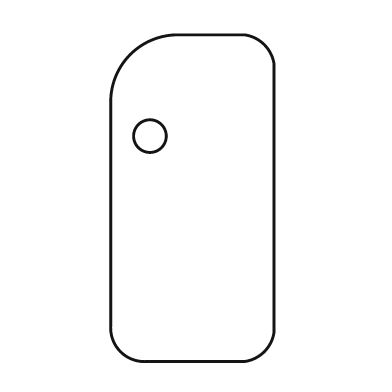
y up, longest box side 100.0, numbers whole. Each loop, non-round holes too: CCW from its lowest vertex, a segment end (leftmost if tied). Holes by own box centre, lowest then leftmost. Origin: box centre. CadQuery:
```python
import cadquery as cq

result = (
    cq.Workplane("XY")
    .moveTo(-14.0, -50.0)
    .lineTo(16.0, -50.0)
    .threePointArc((22.0, -47.0), (25.0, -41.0))
    .lineTo(25.0, 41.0)
    .threePointArc((22.0, 47.0), (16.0, 50.0))
    .lineTo(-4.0, 50.0)
    .threePointArc((-19.0, 44.0), (-25.0, 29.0))
    .lineTo(-25.0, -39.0)
    .threePointArc((-22.0, -47.0), (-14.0, -50.0))
    .close()
    .moveTo(-13.0, 19.0)
    .circle(5.0)
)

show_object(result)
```